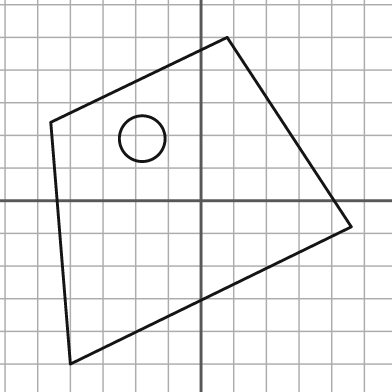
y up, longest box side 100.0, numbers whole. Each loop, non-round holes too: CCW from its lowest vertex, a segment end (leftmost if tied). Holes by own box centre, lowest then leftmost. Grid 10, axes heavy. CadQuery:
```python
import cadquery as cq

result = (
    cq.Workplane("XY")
    .moveTo(-40.0, -50.0)
    .lineTo(46.0, -8.0)
    .lineTo(8.0, 50.0)
    .lineTo(-46.0, 24.0)
    .close()
    .moveTo(-18.0, 19.0)
    .circle(7.0)
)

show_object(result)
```